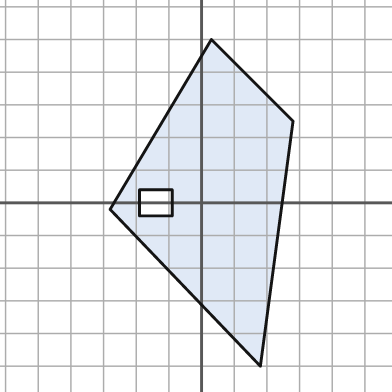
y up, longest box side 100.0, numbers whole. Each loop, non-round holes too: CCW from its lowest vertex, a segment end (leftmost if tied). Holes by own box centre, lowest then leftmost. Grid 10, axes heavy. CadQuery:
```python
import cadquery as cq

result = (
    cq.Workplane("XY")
    .moveTo(18.0, -50.0)
    .lineTo(28.0, 25.0)
    .lineTo(3.0, 50.0)
    .lineTo(-28.0, -2.0)
    .close()
    .moveTo(-19.0, -4.0)
    .lineTo(-9.0, -4.0)
    .lineTo(-9.0, 4.0)
    .lineTo(-19.0, 4.0)
    .close()
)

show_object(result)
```